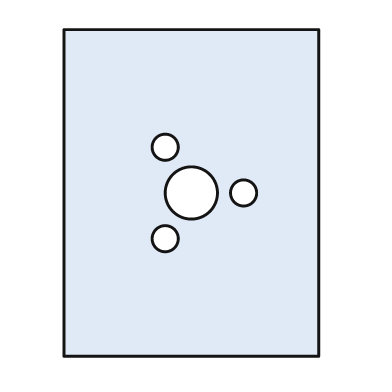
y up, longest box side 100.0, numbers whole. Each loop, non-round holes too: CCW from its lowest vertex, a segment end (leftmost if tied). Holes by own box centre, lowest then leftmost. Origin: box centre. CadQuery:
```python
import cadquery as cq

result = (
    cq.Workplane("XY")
    .moveTo(-39.0, -50.0)
    .lineTo(39.0, -50.0)
    .lineTo(39.0, 50.0)
    .lineTo(-39.0, 50.0)
    .close()
    .moveTo(-8.0, -14.0)
    .circle(4.0)
    .moveTo(0.0, 0.0)
    .circle(8.0)
    .moveTo(16.0, 0.0)
    .circle(4.0)
    .moveTo(-8.0, 14.0)
    .circle(4.0)
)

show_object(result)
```